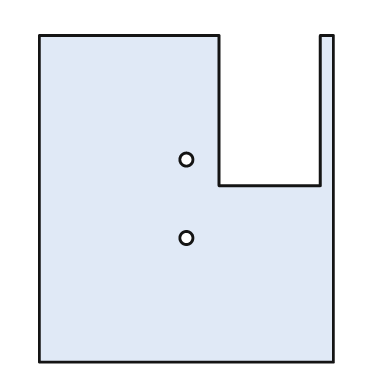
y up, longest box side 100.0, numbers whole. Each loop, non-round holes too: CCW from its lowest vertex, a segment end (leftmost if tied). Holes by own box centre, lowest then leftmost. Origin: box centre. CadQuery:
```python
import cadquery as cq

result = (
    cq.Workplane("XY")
    .moveTo(-45.0, -50.0)
    .lineTo(45.0, -50.0)
    .lineTo(45.0, 50.0)
    .lineTo(41.0, 50.0)
    .lineTo(41.0, 4.0)
    .lineTo(10.0, 4.0)
    .lineTo(10.0, 50.0)
    .lineTo(-45.0, 50.0)
    .close()
    .moveTo(0.0, -12.0)
    .circle(2.0)
    .moveTo(0.0, 12.0)
    .circle(2.0)
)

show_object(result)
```